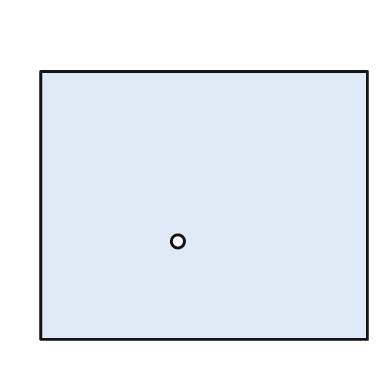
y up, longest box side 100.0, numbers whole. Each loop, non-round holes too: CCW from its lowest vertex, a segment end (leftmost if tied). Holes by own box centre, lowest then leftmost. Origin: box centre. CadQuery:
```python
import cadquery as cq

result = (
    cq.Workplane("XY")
    .moveTo(-50.0, -41.0)
    .lineTo(50.0, -41.0)
    .lineTo(50.0, 41.0)
    .lineTo(-50.0, 41.0)
    .close()
    .moveTo(-8.0, -11.0)
    .circle(2.0)
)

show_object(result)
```